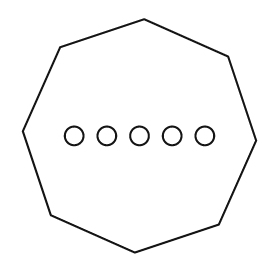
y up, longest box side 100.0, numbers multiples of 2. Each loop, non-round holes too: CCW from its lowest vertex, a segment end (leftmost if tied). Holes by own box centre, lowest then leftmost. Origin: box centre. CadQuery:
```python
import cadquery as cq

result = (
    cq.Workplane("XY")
    .moveTo(-2.0, -50.0)
    .lineTo(34.0, -38.0)
    .lineTo(50.0, -2.0)
    .lineTo(38.0, 34.0)
    .lineTo(2.0, 50.0)
    .lineTo(-34.0, 38.0)
    .lineTo(-50.0, 2.0)
    .lineTo(-38.0, -34.0)
    .close()
    .moveTo(-28.0, 0.0)
    .circle(4.0)
    .moveTo(-14.0, 0.0)
    .circle(4.0)
    .moveTo(0.0, 0.0)
    .circle(4.0)
    .moveTo(14.0, 0.0)
    .circle(4.0)
    .moveTo(28.0, 0.0)
    .circle(4.0)
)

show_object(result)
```